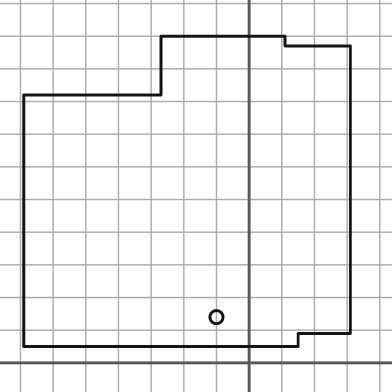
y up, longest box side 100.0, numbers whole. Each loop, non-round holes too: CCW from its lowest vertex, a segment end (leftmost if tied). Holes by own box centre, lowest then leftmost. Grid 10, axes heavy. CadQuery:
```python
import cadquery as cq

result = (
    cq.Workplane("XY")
    .moveTo(-69.0, 5.0)
    .lineTo(15.0, 5.0)
    .lineTo(15.0, 9.0)
    .lineTo(31.0, 9.0)
    .lineTo(31.0, 97.0)
    .lineTo(11.0, 97.0)
    .lineTo(11.0, 100.0)
    .lineTo(-27.0, 100.0)
    .lineTo(-27.0, 82.0)
    .lineTo(-69.0, 82.0)
    .close()
    .moveTo(-10.0, 14.0)
    .circle(2.0)
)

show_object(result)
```